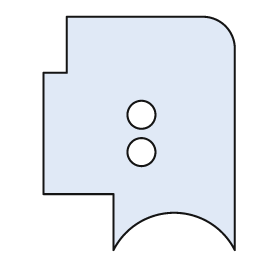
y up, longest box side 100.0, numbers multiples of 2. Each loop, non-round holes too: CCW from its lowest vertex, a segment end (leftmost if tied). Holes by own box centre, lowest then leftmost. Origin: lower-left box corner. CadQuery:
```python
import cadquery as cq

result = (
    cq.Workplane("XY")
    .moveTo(30.0, 0.0)
    .threePointArc((56.0, 16.0), (82.0, 0.0))
    .lineTo(82.0, 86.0)
    .threePointArc((78.0, 96.0), (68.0, 100.0))
    .lineTo(10.0, 100.0)
    .lineTo(10.0, 76.0)
    .lineTo(0.0, 76.0)
    .lineTo(0.0, 24.0)
    .lineTo(30.0, 24.0)
    .close()
    .moveTo(42.0, 42.0)
    .circle(6.0)
    .moveTo(42.0, 58.0)
    .circle(6.0)
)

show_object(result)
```